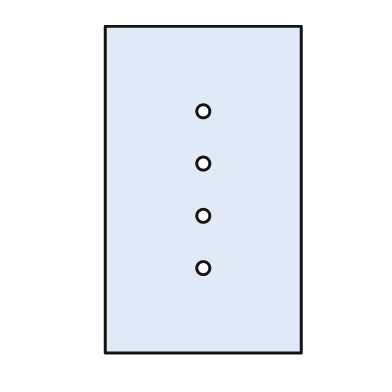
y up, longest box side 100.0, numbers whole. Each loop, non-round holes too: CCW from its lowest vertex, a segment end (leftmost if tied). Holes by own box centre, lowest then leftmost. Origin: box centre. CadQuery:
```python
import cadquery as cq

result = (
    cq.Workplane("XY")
    .moveTo(-30.0, -50.0)
    .lineTo(30.0, -50.0)
    .lineTo(30.0, 50.0)
    .lineTo(-30.0, 50.0)
    .close()
    .moveTo(0.0, -24.0)
    .circle(2.0)
    .moveTo(0.0, -8.0)
    .circle(2.0)
    .moveTo(0.0, 8.0)
    .circle(2.0)
    .moveTo(0.0, 24.0)
    .circle(2.0)
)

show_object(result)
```